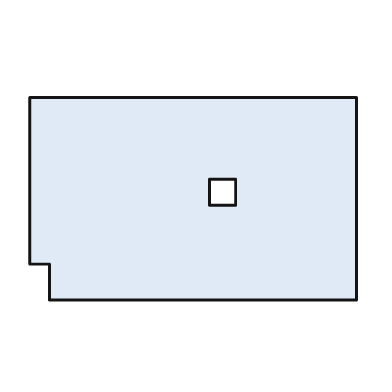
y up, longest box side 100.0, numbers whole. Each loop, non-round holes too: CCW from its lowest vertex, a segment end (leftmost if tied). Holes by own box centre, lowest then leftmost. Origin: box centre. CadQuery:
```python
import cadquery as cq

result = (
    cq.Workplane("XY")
    .moveTo(-44.0, -31.0)
    .lineTo(50.0, -31.0)
    .lineTo(50.0, 31.0)
    .lineTo(-50.0, 31.0)
    .lineTo(-50.0, -20.0)
    .lineTo(-44.0, -20.0)
    .close()
    .moveTo(5.0, -2.0)
    .lineTo(13.0, -2.0)
    .lineTo(13.0, 6.0)
    .lineTo(5.0, 6.0)
    .close()
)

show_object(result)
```